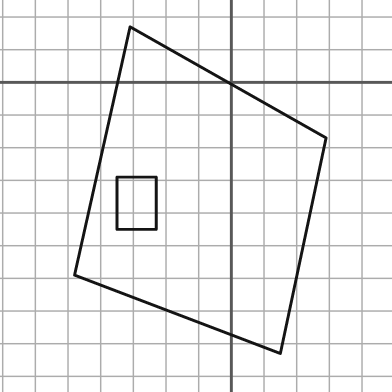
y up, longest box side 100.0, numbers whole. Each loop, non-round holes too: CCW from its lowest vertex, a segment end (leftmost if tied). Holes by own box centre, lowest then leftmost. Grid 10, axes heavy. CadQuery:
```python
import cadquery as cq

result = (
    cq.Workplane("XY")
    .moveTo(15.0, -83.0)
    .lineTo(29.0, -17.0)
    .lineTo(-31.0, 17.0)
    .lineTo(-48.0, -59.0)
    .close()
    .moveTo(-35.0, -45.0)
    .lineTo(-23.0, -45.0)
    .lineTo(-23.0, -29.0)
    .lineTo(-35.0, -29.0)
    .close()
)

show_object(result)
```